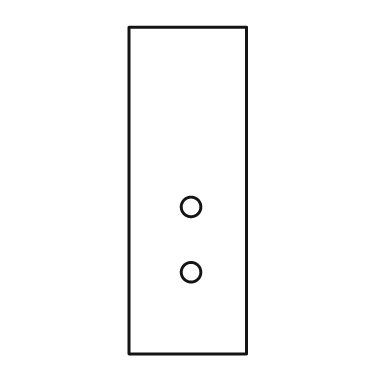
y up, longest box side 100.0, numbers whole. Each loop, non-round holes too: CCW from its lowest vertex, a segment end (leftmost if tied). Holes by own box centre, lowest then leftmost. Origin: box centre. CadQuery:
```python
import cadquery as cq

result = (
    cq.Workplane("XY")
    .moveTo(-18.0, -50.0)
    .lineTo(18.0, -50.0)
    .lineTo(18.0, 50.0)
    .lineTo(-18.0, 50.0)
    .close()
    .moveTo(1.0, -25.0)
    .circle(3.0)
    .moveTo(1.0, -5.0)
    .circle(3.0)
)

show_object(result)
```